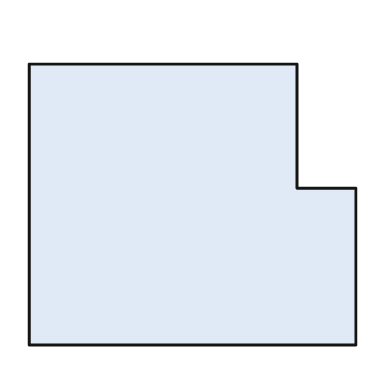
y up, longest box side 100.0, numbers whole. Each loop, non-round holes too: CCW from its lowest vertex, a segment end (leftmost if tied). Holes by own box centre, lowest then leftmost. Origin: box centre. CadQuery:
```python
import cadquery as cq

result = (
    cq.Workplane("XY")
    .moveTo(-50.0, -43.0)
    .lineTo(50.0, -43.0)
    .lineTo(50.0, 5.0)
    .lineTo(32.0, 5.0)
    .lineTo(32.0, 43.0)
    .lineTo(-50.0, 43.0)
    .close()
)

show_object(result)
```